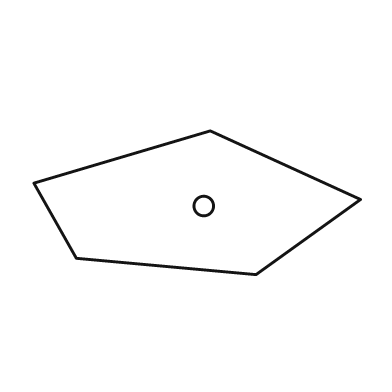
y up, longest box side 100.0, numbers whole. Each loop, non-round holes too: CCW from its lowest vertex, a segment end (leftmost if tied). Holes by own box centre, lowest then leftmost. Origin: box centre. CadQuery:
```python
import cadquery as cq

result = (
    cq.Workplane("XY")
    .moveTo(18.0, -22.0)
    .lineTo(50.0, 1.0)
    .lineTo(4.0, 22.0)
    .lineTo(-50.0, 6.0)
    .lineTo(-37.0, -17.0)
    .close()
    .moveTo(2.0, -1.0)
    .circle(3.0)
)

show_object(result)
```